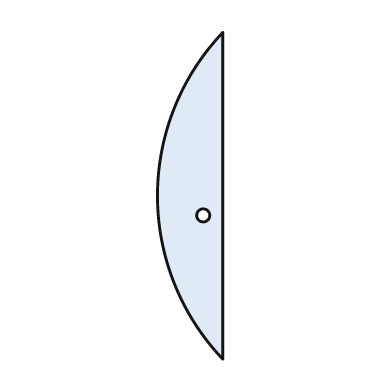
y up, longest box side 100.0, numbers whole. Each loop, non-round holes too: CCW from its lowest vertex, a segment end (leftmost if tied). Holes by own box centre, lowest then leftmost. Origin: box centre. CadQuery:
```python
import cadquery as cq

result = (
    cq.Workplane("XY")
    .moveTo(10.0, -50.0)
    .lineTo(10.0, 50.0)
    .threePointArc((-10.0, 0.0), (10.0, -50.0))
    .close()
    .moveTo(4.0, -6.0)
    .circle(2.0)
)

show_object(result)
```